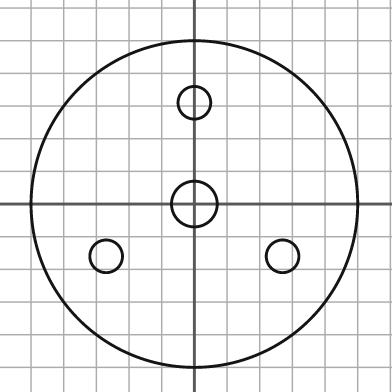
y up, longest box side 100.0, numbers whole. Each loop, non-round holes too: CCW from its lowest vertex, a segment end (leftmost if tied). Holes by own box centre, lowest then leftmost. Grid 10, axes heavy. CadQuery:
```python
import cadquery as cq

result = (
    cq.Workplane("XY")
    .moveTo(0.0, 0.0)
    .circle(50.0)
    .moveTo(-27.0, -16.0)
    .circle(5.0)
    .moveTo(27.0, -16.0)
    .circle(5.0)
    .moveTo(0.0, 0.0)
    .circle(7.0)
    .moveTo(0.0, 31.0)
    .circle(5.0)
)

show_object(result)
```